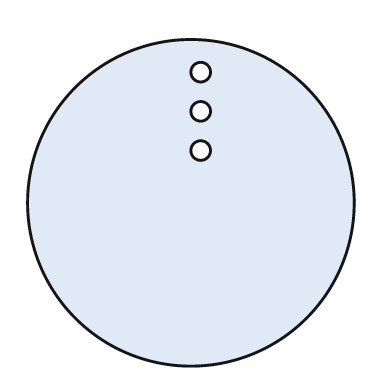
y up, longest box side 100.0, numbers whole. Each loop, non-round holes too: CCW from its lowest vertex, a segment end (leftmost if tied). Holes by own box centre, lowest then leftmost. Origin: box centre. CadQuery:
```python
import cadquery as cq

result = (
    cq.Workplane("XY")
    .moveTo(0.0, 0.0)
    .circle(50.0)
    .moveTo(3.0, 16.0)
    .circle(3.0)
    .moveTo(3.0, 28.0)
    .circle(3.0)
    .moveTo(3.0, 40.0)
    .circle(3.0)
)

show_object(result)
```